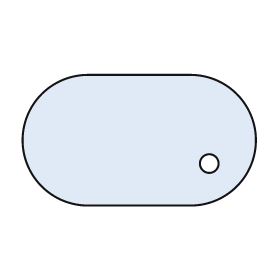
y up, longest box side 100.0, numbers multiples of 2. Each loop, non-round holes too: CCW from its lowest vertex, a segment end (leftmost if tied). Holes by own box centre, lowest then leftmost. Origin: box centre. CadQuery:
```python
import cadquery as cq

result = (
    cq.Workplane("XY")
    .moveTo(-22.0, -28.0)
    .lineTo(22.0, -28.0)
    .threePointArc((50.0, 0.0), (22.0, 28.0))
    .lineTo(-22.0, 28.0)
    .threePointArc((-50.0, 0.0), (-22.0, -28.0))
    .close()
    .moveTo(30.0, -10.0)
    .circle(4.0)
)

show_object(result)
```